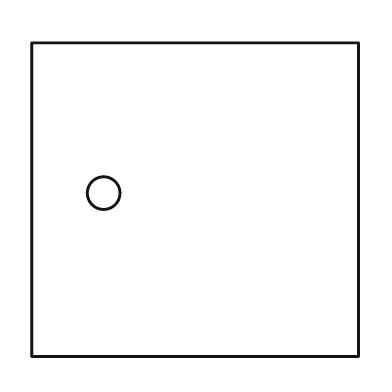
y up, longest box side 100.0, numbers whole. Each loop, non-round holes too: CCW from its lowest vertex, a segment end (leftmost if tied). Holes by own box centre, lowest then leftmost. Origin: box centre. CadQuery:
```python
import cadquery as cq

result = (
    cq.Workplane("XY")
    .moveTo(-50.0, -48.0)
    .lineTo(50.0, -48.0)
    .lineTo(50.0, 48.0)
    .lineTo(-50.0, 48.0)
    .close()
    .moveTo(-28.0, 2.0)
    .circle(5.0)
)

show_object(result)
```